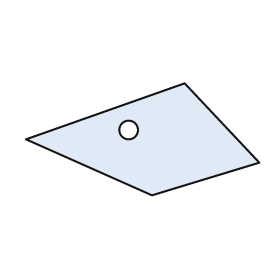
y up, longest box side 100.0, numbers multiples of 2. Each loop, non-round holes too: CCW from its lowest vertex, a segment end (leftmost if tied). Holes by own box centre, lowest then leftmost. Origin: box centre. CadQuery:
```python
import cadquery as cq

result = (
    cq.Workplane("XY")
    .moveTo(4.0, -24.0)
    .lineTo(50.0, -10.0)
    .lineTo(18.0, 24.0)
    .lineTo(-50.0, 0.0)
    .close()
    .moveTo(-6.0, 4.0)
    .circle(4.0)
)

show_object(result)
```